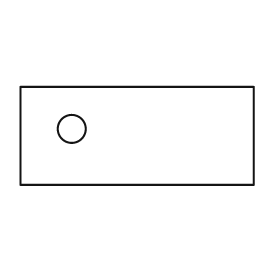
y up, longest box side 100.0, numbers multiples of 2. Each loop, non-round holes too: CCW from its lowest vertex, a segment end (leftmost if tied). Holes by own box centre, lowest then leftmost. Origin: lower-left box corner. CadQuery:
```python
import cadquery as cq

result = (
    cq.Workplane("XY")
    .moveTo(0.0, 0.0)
    .lineTo(100.0, 0.0)
    .lineTo(100.0, 42.0)
    .lineTo(0.0, 42.0)
    .close()
    .moveTo(22.0, 24.0)
    .circle(6.0)
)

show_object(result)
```